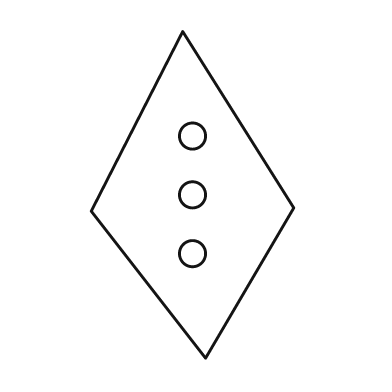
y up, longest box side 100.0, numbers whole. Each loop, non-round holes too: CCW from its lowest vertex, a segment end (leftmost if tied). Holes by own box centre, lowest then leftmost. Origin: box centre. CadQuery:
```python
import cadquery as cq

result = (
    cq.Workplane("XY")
    .moveTo(4.0, -50.0)
    .lineTo(31.0, -4.0)
    .lineTo(-3.0, 50.0)
    .lineTo(-31.0, -5.0)
    .close()
    .moveTo(0.0, -18.0)
    .circle(4.0)
    .moveTo(0.0, 0.0)
    .circle(4.0)
    .moveTo(0.0, 18.0)
    .circle(4.0)
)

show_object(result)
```